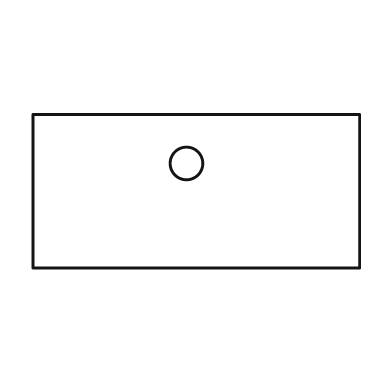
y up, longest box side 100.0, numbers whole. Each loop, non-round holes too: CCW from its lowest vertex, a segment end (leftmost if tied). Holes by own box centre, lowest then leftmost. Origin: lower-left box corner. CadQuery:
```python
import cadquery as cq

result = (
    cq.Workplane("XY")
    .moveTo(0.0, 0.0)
    .lineTo(100.0, 0.0)
    .lineTo(100.0, 47.0)
    .lineTo(0.0, 47.0)
    .close()
    .moveTo(47.0, 32.0)
    .circle(5.0)
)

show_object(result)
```